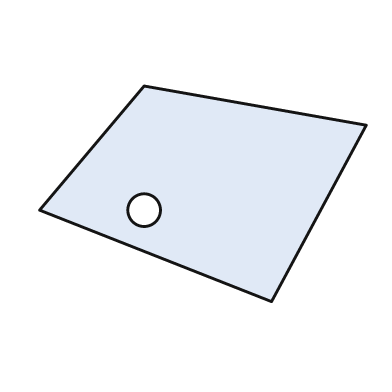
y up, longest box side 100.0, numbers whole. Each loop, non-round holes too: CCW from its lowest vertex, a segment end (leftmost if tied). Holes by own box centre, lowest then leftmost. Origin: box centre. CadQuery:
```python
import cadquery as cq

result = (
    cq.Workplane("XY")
    .moveTo(21.0, -33.0)
    .lineTo(50.0, 21.0)
    .lineTo(-18.0, 33.0)
    .lineTo(-50.0, -5.0)
    .close()
    .moveTo(-18.0, -5.0)
    .circle(5.0)
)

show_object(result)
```